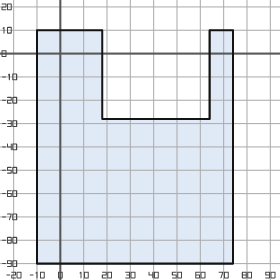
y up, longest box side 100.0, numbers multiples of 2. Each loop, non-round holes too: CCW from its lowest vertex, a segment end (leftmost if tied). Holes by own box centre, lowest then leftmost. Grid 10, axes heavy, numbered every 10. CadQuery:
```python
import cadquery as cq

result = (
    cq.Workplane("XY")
    .moveTo(-10.0, -90.0)
    .lineTo(74.0, -90.0)
    .lineTo(74.0, 10.0)
    .lineTo(64.0, 10.0)
    .lineTo(64.0, -28.0)
    .lineTo(18.0, -28.0)
    .lineTo(18.0, 10.0)
    .lineTo(-10.0, 10.0)
    .close()
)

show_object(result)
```